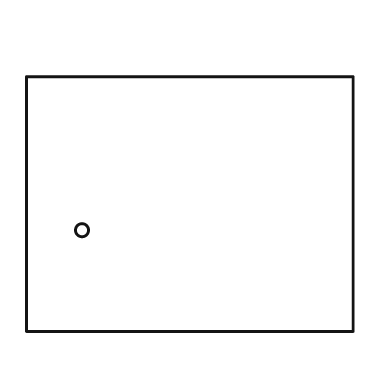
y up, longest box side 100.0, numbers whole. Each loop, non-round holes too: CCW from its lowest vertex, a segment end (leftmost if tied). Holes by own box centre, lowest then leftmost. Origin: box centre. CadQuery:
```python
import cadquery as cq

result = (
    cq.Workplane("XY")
    .moveTo(-50.0, -39.0)
    .lineTo(50.0, -39.0)
    .lineTo(50.0, 39.0)
    .lineTo(-50.0, 39.0)
    .close()
    .moveTo(-33.0, -8.0)
    .circle(2.0)
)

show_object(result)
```